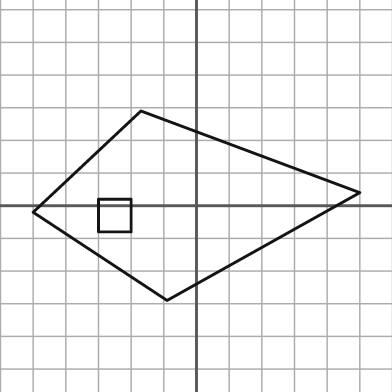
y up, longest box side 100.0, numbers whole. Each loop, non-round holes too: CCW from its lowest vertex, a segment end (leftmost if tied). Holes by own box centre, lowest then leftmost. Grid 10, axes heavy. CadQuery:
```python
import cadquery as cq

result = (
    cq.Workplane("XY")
    .moveTo(-9.0, -29.0)
    .lineTo(50.0, 4.0)
    .lineTo(-17.0, 29.0)
    .lineTo(-50.0, -2.0)
    .close()
    .moveTo(-30.0, -8.0)
    .lineTo(-20.0, -8.0)
    .lineTo(-20.0, 2.0)
    .lineTo(-30.0, 2.0)
    .close()
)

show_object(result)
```